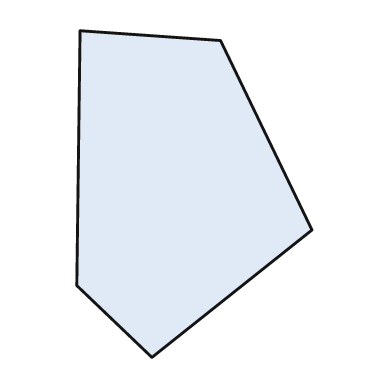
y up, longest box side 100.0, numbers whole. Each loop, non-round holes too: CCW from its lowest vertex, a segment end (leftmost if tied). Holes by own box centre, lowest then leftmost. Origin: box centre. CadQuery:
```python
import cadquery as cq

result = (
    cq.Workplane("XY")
    .moveTo(-13.0, -50.0)
    .lineTo(36.0, -11.0)
    .lineTo(8.0, 47.0)
    .lineTo(-35.0, 50.0)
    .lineTo(-36.0, -28.0)
    .close()
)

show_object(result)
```